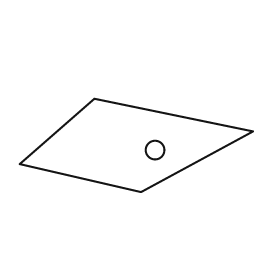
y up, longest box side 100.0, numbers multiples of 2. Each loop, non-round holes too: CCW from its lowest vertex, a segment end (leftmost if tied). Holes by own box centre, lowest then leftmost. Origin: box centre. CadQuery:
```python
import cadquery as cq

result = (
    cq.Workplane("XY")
    .moveTo(2.0, -20.0)
    .lineTo(50.0, 6.0)
    .lineTo(-18.0, 20.0)
    .lineTo(-50.0, -8.0)
    .close()
    .moveTo(8.0, -2.0)
    .circle(4.0)
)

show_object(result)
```